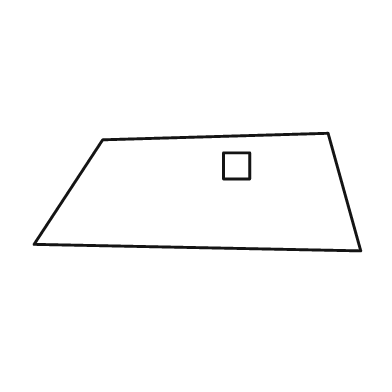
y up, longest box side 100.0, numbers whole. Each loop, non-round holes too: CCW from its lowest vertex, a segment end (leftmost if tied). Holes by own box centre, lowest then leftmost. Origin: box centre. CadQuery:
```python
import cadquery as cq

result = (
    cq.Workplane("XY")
    .moveTo(50.0, -18.0)
    .lineTo(40.0, 18.0)
    .lineTo(-29.0, 16.0)
    .lineTo(-50.0, -16.0)
    .close()
    .moveTo(8.0, 4.0)
    .lineTo(16.0, 4.0)
    .lineTo(16.0, 12.0)
    .lineTo(8.0, 12.0)
    .close()
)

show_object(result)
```